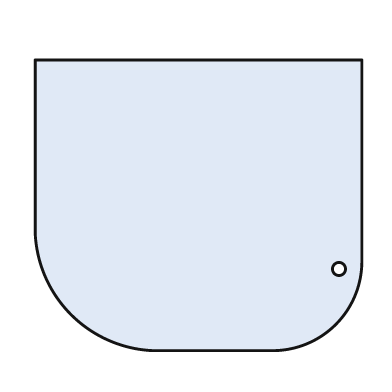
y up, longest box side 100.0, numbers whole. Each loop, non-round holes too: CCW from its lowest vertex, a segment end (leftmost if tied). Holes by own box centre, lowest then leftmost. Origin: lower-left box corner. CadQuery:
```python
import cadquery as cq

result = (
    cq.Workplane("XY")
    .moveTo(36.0, 0.0)
    .lineTo(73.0, 0.0)
    .threePointArc((92.0, 8.0), (100.0, 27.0))
    .lineTo(100.0, 89.0)
    .lineTo(0.0, 89.0)
    .lineTo(0.0, 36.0)
    .threePointArc((11.0, 11.0), (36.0, 0.0))
    .close()
    .moveTo(93.0, 25.0)
    .circle(2.0)
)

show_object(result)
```